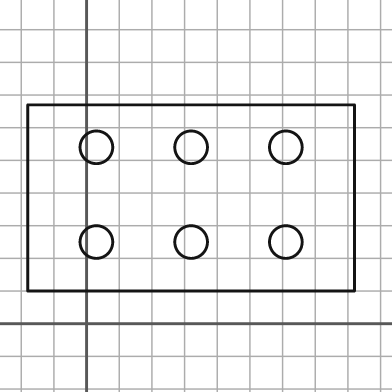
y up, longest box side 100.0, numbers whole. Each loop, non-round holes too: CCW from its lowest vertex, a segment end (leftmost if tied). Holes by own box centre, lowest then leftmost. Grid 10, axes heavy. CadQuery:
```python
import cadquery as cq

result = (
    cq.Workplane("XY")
    .moveTo(-18.0, 10.0)
    .lineTo(82.0, 10.0)
    .lineTo(82.0, 67.0)
    .lineTo(-18.0, 67.0)
    .close()
    .moveTo(3.0, 25.0)
    .circle(5.0)
    .moveTo(32.0, 25.0)
    .circle(5.0)
    .moveTo(61.0, 25.0)
    .circle(5.0)
    .moveTo(3.0, 54.0)
    .circle(5.0)
    .moveTo(32.0, 54.0)
    .circle(5.0)
    .moveTo(61.0, 54.0)
    .circle(5.0)
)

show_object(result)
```